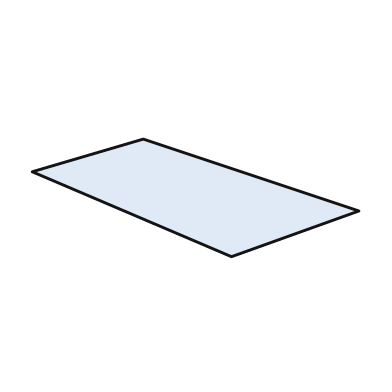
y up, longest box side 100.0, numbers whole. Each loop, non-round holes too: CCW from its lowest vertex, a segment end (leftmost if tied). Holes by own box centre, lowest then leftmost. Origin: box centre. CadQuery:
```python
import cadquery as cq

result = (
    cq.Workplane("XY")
    .moveTo(11.0, -18.0)
    .lineTo(50.0, -4.0)
    .lineTo(-16.0, 18.0)
    .lineTo(-50.0, 8.0)
    .close()
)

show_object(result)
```